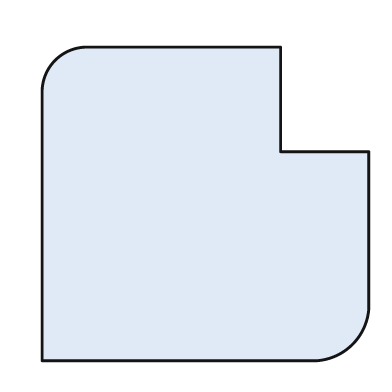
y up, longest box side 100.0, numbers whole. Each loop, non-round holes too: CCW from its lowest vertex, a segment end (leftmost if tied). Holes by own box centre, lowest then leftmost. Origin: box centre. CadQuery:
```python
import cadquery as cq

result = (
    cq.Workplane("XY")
    .moveTo(-50.0, -48.0)
    .lineTo(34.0, -48.0)
    .threePointArc((45.0, -43.0), (50.0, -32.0))
    .lineTo(50.0, 16.0)
    .lineTo(23.0, 16.0)
    .lineTo(23.0, 48.0)
    .lineTo(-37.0, 48.0)
    .threePointArc((-46.0, 44.0), (-50.0, 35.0))
    .close()
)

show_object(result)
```